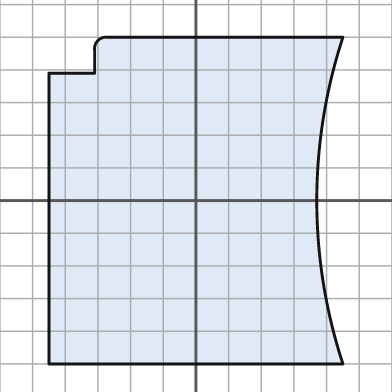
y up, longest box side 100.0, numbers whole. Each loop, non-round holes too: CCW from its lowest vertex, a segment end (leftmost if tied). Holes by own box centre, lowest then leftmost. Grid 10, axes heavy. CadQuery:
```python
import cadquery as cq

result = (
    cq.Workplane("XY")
    .moveTo(-45.0, -50.0)
    .lineTo(45.0, -50.0)
    .threePointArc((37.0, 0.0), (45.0, 50.0))
    .lineTo(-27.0, 50.0)
    .threePointArc((-30.0, 49.0), (-31.0, 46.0))
    .lineTo(-31.0, 39.0)
    .lineTo(-45.0, 39.0)
    .close()
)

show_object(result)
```